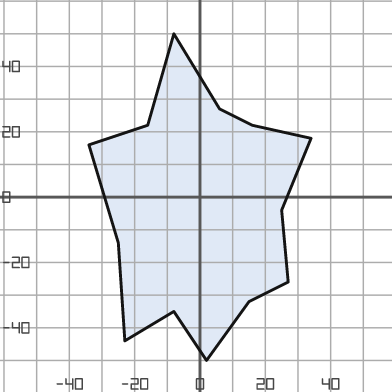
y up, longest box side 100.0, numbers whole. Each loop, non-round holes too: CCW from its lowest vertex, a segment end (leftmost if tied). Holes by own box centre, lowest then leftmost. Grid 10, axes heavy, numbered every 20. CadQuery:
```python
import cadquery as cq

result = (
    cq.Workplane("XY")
    .moveTo(2.0, -50.0)
    .lineTo(15.0, -32.0)
    .lineTo(27.0, -26.0)
    .lineTo(25.0, -4.0)
    .lineTo(34.0, 18.0)
    .lineTo(16.0, 22.0)
    .lineTo(6.0, 27.0)
    .lineTo(-8.0, 50.0)
    .lineTo(-16.0, 22.0)
    .lineTo(-34.0, 16.0)
    .lineTo(-25.0, -14.0)
    .lineTo(-23.0, -44.0)
    .lineTo(-8.0, -35.0)
    .close()
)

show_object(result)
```